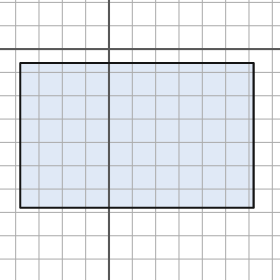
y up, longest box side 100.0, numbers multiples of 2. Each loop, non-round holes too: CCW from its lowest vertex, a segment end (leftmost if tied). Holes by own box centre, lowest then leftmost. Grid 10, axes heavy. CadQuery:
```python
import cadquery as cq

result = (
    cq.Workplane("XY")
    .moveTo(-38.0, -68.0)
    .lineTo(62.0, -68.0)
    .lineTo(62.0, -6.0)
    .lineTo(-38.0, -6.0)
    .close()
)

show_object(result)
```